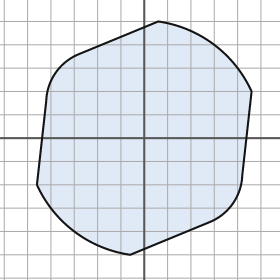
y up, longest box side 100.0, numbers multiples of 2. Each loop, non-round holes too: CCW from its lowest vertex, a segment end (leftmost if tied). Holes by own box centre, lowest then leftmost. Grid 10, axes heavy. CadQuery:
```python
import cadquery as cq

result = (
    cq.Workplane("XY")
    .moveTo(-6.0, -50.0)
    .lineTo(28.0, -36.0)
    .threePointArc((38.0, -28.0), (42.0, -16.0))
    .lineTo(46.0, 20.0)
    .threePointArc((30.0, 40.0), (6.0, 50.0))
    .lineTo(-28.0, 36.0)
    .threePointArc((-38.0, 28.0), (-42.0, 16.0))
    .lineTo(-46.0, -20.0)
    .threePointArc((-30.0, -40.0), (-6.0, -50.0))
    .close()
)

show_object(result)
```